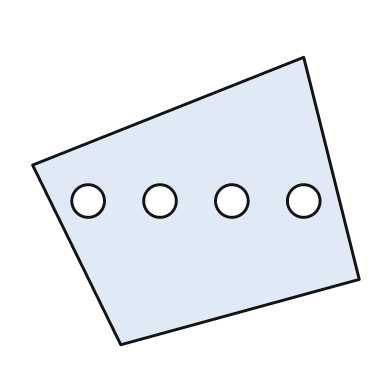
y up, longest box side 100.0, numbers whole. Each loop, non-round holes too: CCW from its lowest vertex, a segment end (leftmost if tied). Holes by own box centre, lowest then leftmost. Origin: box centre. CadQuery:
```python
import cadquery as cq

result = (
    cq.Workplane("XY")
    .moveTo(-23.0, -44.0)
    .lineTo(50.0, -24.0)
    .lineTo(33.0, 44.0)
    .lineTo(-50.0, 11.0)
    .close()
    .moveTo(-33.0, 0.0)
    .circle(5.0)
    .moveTo(-11.0, 0.0)
    .circle(5.0)
    .moveTo(11.0, 0.0)
    .circle(5.0)
    .moveTo(33.0, 0.0)
    .circle(5.0)
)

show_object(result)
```